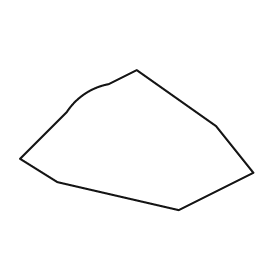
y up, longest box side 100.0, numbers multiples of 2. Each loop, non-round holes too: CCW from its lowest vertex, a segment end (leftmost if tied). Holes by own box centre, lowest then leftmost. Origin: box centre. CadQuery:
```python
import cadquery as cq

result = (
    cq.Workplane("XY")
    .moveTo(18.0, -30.0)
    .lineTo(50.0, -14.0)
    .lineTo(34.0, 6.0)
    .lineTo(0.0, 30.0)
    .lineTo(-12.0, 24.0)
    .threePointArc((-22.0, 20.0), (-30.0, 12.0))
    .lineTo(-50.0, -8.0)
    .lineTo(-34.0, -18.0)
    .close()
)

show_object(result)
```